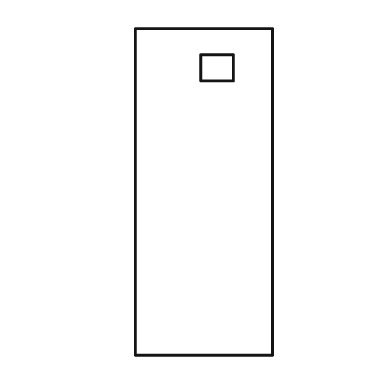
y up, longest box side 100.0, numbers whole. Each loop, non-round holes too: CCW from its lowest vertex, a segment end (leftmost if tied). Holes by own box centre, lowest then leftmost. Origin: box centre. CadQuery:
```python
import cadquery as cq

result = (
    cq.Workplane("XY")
    .moveTo(-21.0, -50.0)
    .lineTo(21.0, -50.0)
    .lineTo(21.0, 50.0)
    .lineTo(-21.0, 50.0)
    .close()
    .moveTo(-1.0, 34.0)
    .lineTo(9.0, 34.0)
    .lineTo(9.0, 42.0)
    .lineTo(-1.0, 42.0)
    .close()
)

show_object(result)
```